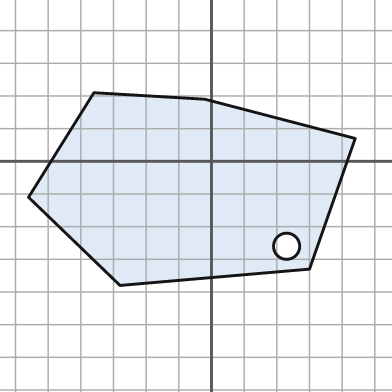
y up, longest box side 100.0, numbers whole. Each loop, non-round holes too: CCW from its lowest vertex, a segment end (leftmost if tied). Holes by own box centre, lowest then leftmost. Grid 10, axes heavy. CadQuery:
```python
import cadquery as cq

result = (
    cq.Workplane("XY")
    .moveTo(-28.0, -38.0)
    .lineTo(30.0, -33.0)
    .lineTo(44.0, 7.0)
    .lineTo(-2.0, 19.0)
    .lineTo(-36.0, 21.0)
    .lineTo(-56.0, -11.0)
    .close()
    .moveTo(23.0, -26.0)
    .circle(4.0)
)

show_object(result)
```